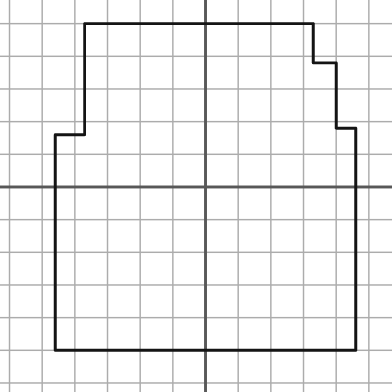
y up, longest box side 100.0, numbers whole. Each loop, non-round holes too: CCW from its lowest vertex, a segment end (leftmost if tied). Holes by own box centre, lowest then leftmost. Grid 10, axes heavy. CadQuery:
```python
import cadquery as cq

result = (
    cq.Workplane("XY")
    .moveTo(-46.0, -50.0)
    .lineTo(46.0, -50.0)
    .lineTo(46.0, 18.0)
    .lineTo(40.0, 18.0)
    .lineTo(40.0, 38.0)
    .lineTo(33.0, 38.0)
    .lineTo(33.0, 50.0)
    .lineTo(-37.0, 50.0)
    .lineTo(-37.0, 16.0)
    .lineTo(-46.0, 16.0)
    .close()
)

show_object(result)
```